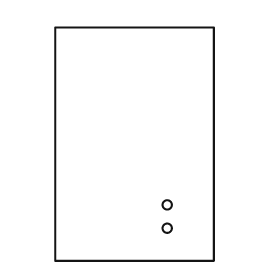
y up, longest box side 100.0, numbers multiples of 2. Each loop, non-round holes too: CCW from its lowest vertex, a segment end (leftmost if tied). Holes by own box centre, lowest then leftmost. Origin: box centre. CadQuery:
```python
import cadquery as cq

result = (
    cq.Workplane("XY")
    .moveTo(-34.0, -50.0)
    .lineTo(34.0, -50.0)
    .lineTo(34.0, 50.0)
    .lineTo(-34.0, 50.0)
    .close()
    .moveTo(14.0, -36.0)
    .circle(2.0)
    .moveTo(14.0, -26.0)
    .circle(2.0)
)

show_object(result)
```